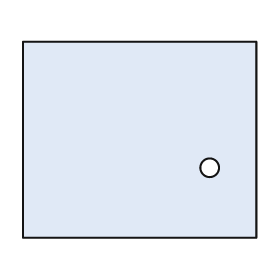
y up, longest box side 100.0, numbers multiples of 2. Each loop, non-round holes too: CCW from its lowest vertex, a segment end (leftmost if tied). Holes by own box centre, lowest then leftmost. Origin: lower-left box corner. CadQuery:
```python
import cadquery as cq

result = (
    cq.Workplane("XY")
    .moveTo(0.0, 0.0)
    .lineTo(100.0, 0.0)
    .lineTo(100.0, 84.0)
    .lineTo(0.0, 84.0)
    .close()
    .moveTo(80.0, 30.0)
    .circle(4.0)
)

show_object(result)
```